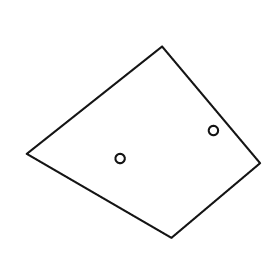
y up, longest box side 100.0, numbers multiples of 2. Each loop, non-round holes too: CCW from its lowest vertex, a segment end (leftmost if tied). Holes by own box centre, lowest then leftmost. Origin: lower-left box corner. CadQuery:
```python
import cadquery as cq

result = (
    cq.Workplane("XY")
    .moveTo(62.0, 0.0)
    .lineTo(100.0, 32.0)
    .lineTo(58.0, 82.0)
    .lineTo(0.0, 36.0)
    .close()
    .moveTo(40.0, 34.0)
    .circle(2.0)
    .moveTo(80.0, 46.0)
    .circle(2.0)
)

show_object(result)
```